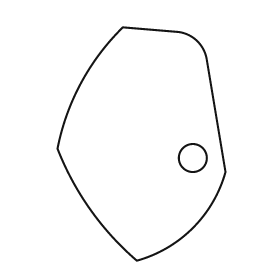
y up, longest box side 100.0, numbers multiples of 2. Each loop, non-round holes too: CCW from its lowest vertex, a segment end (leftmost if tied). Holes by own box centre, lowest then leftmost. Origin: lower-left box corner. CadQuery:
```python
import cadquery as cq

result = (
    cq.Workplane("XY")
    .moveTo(34.0, 0.0)
    .threePointArc((58.0, 14.0), (72.0, 38.0))
    .lineTo(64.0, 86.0)
    .threePointArc((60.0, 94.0), (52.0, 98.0))
    .lineTo(28.0, 100.0)
    .threePointArc((10.0, 76.0), (0.0, 48.0))
    .threePointArc((14.0, 22.0), (34.0, 0.0))
    .close()
    .moveTo(58.0, 44.0)
    .circle(6.0)
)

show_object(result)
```